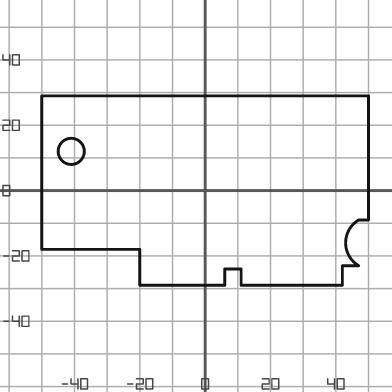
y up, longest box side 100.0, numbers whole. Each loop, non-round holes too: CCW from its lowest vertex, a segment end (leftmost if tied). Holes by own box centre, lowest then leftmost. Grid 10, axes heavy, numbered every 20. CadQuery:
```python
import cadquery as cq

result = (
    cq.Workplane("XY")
    .moveTo(-20.0, -29.0)
    .lineTo(6.0, -29.0)
    .lineTo(6.0, -24.0)
    .lineTo(11.0, -24.0)
    .lineTo(11.0, -29.0)
    .lineTo(42.0, -29.0)
    .lineTo(42.0, -23.0)
    .lineTo(47.0, -23.0)
    .threePointArc((43.0, -16.0), (47.0, -9.0))
    .lineTo(50.0, -9.0)
    .lineTo(50.0, 29.0)
    .lineTo(-50.0, 29.0)
    .lineTo(-50.0, -18.0)
    .lineTo(-20.0, -18.0)
    .close()
    .moveTo(-41.0, 12.0)
    .circle(4.0)
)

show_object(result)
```